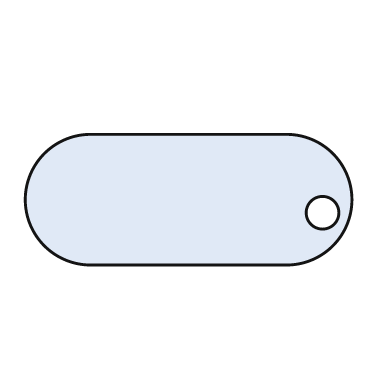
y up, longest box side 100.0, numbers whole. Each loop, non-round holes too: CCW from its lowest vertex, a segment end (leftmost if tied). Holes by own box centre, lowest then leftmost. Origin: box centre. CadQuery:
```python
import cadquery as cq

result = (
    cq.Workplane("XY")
    .moveTo(-30.0, -20.0)
    .lineTo(30.0, -20.0)
    .threePointArc((50.0, 0.0), (30.0, 20.0))
    .lineTo(-30.0, 20.0)
    .threePointArc((-50.0, 0.0), (-30.0, -20.0))
    .close()
    .moveTo(41.0, -4.0)
    .circle(5.0)
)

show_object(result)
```